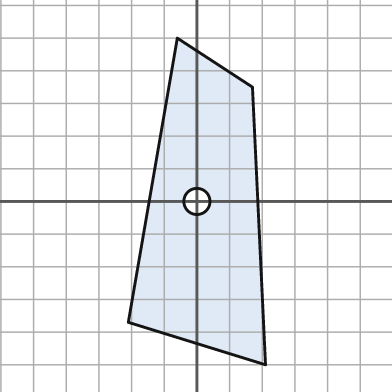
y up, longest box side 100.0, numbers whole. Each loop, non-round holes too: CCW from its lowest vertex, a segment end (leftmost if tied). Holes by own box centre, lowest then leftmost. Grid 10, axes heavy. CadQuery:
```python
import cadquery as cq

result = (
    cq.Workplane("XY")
    .moveTo(21.0, -50.0)
    .lineTo(17.0, 35.0)
    .lineTo(-6.0, 50.0)
    .lineTo(-21.0, -37.0)
    .close()
    .moveTo(0.0, 0.0)
    .circle(4.0)
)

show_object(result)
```